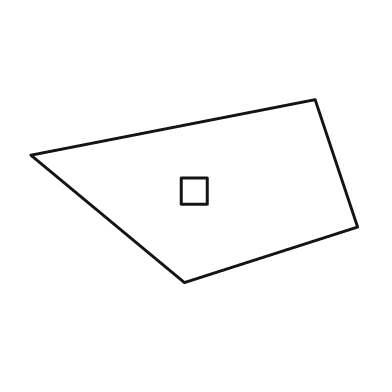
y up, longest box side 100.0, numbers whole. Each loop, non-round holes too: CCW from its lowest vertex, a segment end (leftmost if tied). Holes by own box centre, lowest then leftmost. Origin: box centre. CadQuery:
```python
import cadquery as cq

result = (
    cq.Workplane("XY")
    .moveTo(-3.0, -28.0)
    .lineTo(50.0, -11.0)
    .lineTo(37.0, 28.0)
    .lineTo(-50.0, 11.0)
    .close()
    .moveTo(-4.0, -4.0)
    .lineTo(4.0, -4.0)
    .lineTo(4.0, 4.0)
    .lineTo(-4.0, 4.0)
    .close()
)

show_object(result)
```